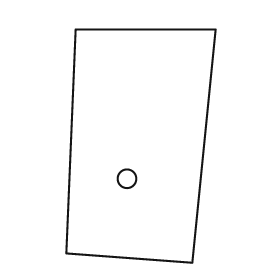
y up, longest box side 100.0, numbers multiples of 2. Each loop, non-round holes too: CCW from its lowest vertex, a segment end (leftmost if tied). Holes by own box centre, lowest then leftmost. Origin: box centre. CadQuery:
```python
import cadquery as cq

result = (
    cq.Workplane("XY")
    .moveTo(22.0, -50.0)
    .lineTo(32.0, 50.0)
    .lineTo(-28.0, 50.0)
    .lineTo(-32.0, -46.0)
    .close()
    .moveTo(-6.0, -14.0)
    .circle(4.0)
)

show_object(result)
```